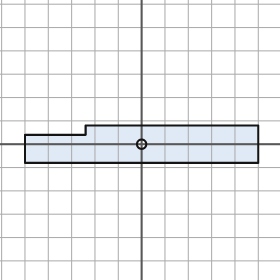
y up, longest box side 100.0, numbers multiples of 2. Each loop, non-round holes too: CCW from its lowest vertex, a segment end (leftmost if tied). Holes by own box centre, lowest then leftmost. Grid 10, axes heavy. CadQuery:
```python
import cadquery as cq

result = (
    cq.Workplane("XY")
    .moveTo(-50.0, -8.0)
    .lineTo(50.0, -8.0)
    .lineTo(50.0, 8.0)
    .lineTo(-24.0, 8.0)
    .lineTo(-24.0, 4.0)
    .lineTo(-50.0, 4.0)
    .close()
    .moveTo(0.0, 0.0)
    .circle(2.0)
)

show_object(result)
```